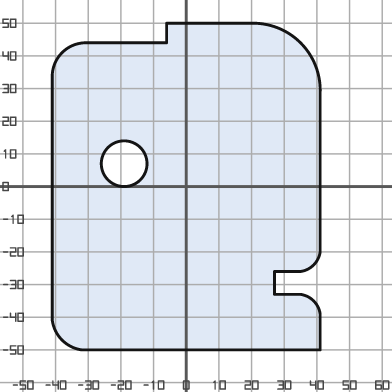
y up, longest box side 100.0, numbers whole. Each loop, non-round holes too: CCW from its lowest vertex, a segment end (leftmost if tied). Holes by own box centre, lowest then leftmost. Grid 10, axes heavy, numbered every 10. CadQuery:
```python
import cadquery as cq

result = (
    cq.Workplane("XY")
    .moveTo(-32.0, -50.0)
    .lineTo(41.0, -50.0)
    .lineTo(41.0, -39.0)
    .threePointArc((39.0, -35.0), (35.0, -33.0))
    .lineTo(27.0, -33.0)
    .lineTo(27.0, -26.0)
    .lineTo(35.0, -26.0)
    .threePointArc((39.0, -24.0), (41.0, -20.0))
    .lineTo(41.0, 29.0)
    .threePointArc((35.0, 44.0), (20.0, 50.0))
    .lineTo(-6.0, 50.0)
    .lineTo(-6.0, 44.0)
    .lineTo(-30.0, 44.0)
    .threePointArc((-38.0, 41.0), (-41.0, 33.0))
    .lineTo(-41.0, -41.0)
    .threePointArc((-38.0, -47.0), (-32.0, -50.0))
    .close()
    .moveTo(-19.0, 7.0)
    .circle(7.0)
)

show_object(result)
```